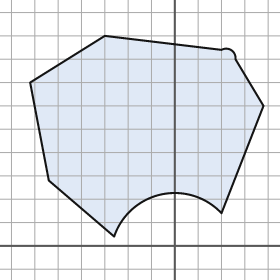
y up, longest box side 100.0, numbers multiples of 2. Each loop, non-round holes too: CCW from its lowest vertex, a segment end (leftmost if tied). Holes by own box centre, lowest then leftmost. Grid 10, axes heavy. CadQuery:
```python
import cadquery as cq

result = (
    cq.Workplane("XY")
    .moveTo(-26.0, 4.0)
    .threePointArc((-6.0, 22.0), (20.0, 14.0))
    .lineTo(38.0, 60.0)
    .lineTo(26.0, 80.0)
    .threePointArc((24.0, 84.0), (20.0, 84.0))
    .lineTo(-30.0, 90.0)
    .lineTo(-62.0, 70.0)
    .lineTo(-54.0, 28.0)
    .close()
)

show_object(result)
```